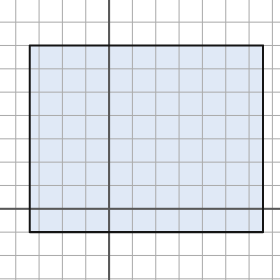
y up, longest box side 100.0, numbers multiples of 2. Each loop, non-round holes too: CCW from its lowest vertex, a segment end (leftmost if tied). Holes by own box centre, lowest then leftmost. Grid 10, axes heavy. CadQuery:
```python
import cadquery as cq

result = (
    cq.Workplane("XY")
    .moveTo(-34.0, -10.0)
    .lineTo(66.0, -10.0)
    .lineTo(66.0, 70.0)
    .lineTo(-34.0, 70.0)
    .close()
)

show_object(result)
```